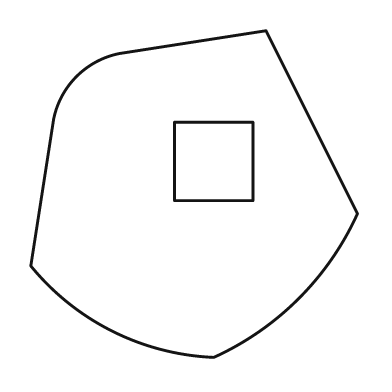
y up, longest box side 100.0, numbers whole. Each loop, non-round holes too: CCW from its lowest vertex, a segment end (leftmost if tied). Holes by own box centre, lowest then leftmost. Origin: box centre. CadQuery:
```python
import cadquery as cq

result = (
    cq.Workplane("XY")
    .moveTo(6.0, -50.0)
    .threePointArc((32.0, -32.0), (50.0, -6.0))
    .lineTo(22.0, 50.0)
    .lineTo(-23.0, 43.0)
    .threePointArc((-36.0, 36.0), (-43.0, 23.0))
    .lineTo(-50.0, -22.0)
    .threePointArc((-25.0, -42.0), (6.0, -50.0))
    .close()
    .moveTo(-6.0, -2.0)
    .lineTo(18.0, -2.0)
    .lineTo(18.0, 22.0)
    .lineTo(-6.0, 22.0)
    .close()
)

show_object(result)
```